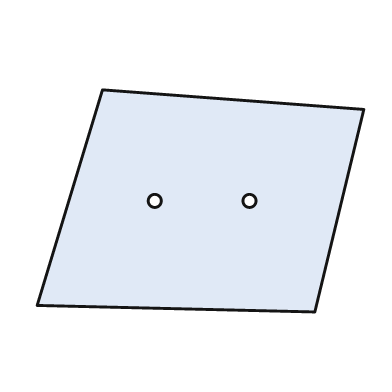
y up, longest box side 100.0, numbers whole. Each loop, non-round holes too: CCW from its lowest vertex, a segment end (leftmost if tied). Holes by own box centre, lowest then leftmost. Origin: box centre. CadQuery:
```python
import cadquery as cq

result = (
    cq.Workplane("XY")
    .moveTo(35.0, -34.0)
    .lineTo(50.0, 28.0)
    .lineTo(-30.0, 34.0)
    .lineTo(-50.0, -32.0)
    .close()
    .moveTo(-14.0, 0.0)
    .circle(2.0)
    .moveTo(15.0, 0.0)
    .circle(2.0)
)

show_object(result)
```